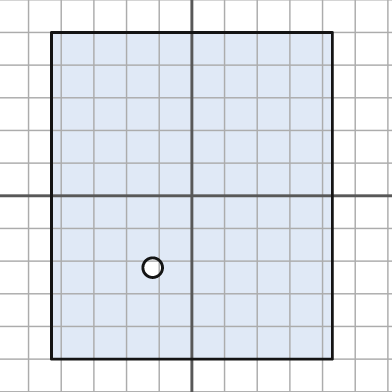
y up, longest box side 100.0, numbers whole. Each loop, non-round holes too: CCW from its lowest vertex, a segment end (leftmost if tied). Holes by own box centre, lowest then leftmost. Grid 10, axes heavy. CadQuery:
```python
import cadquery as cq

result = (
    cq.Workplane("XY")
    .moveTo(-43.0, -50.0)
    .lineTo(43.0, -50.0)
    .lineTo(43.0, 50.0)
    .lineTo(-43.0, 50.0)
    .close()
    .moveTo(-12.0, -22.0)
    .circle(3.0)
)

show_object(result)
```